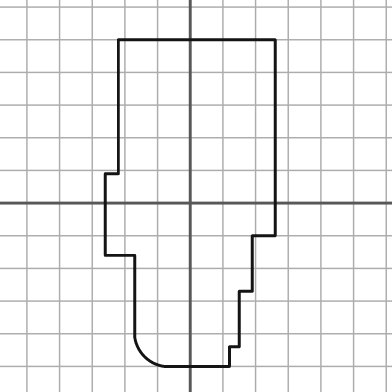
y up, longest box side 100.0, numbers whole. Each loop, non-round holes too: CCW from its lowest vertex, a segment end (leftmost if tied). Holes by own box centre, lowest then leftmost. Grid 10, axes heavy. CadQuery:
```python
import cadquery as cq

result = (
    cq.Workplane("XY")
    .moveTo(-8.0, -50.0)
    .lineTo(12.0, -50.0)
    .lineTo(12.0, -44.0)
    .lineTo(15.0, -44.0)
    .lineTo(15.0, -27.0)
    .lineTo(19.0, -27.0)
    .lineTo(19.0, -10.0)
    .lineTo(26.0, -10.0)
    .lineTo(26.0, 50.0)
    .lineTo(-22.0, 50.0)
    .lineTo(-22.0, 9.0)
    .lineTo(-26.0, 9.0)
    .lineTo(-26.0, -16.0)
    .lineTo(-17.0, -16.0)
    .lineTo(-17.0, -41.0)
    .threePointArc((-14.0, -47.0), (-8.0, -50.0))
    .close()
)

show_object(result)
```